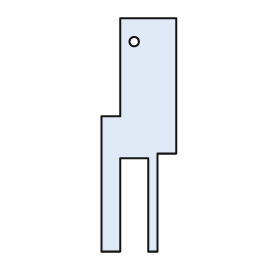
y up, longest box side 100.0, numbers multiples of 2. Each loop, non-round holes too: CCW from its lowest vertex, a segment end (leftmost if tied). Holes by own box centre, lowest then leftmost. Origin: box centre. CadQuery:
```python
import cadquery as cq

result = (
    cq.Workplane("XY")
    .moveTo(-16.0, -50.0)
    .lineTo(-8.0, -50.0)
    .lineTo(-8.0, -10.0)
    .lineTo(4.0, -10.0)
    .lineTo(4.0, -50.0)
    .lineTo(8.0, -50.0)
    .lineTo(8.0, -8.0)
    .lineTo(16.0, -8.0)
    .lineTo(16.0, 50.0)
    .lineTo(-8.0, 50.0)
    .lineTo(-8.0, 8.0)
    .lineTo(-16.0, 8.0)
    .close()
    .moveTo(-2.0, 40.0)
    .circle(2.0)
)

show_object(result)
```